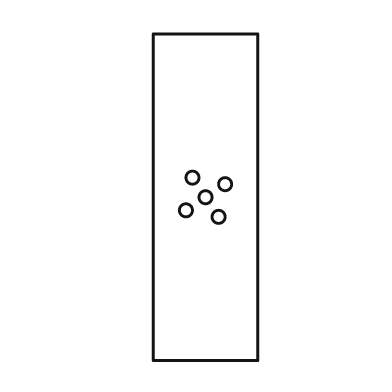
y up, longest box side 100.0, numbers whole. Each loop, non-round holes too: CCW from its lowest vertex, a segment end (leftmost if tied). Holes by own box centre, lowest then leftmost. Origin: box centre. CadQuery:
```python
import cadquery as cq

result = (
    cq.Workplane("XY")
    .moveTo(-16.0, -50.0)
    .lineTo(16.0, -50.0)
    .lineTo(16.0, 50.0)
    .lineTo(-16.0, 50.0)
    .close()
    .moveTo(4.0, -6.0)
    .circle(2.0)
    .moveTo(-6.0, -4.0)
    .circle(2.0)
    .moveTo(0.0, 0.0)
    .circle(2.0)
    .moveTo(6.0, 4.0)
    .circle(2.0)
    .moveTo(-4.0, 6.0)
    .circle(2.0)
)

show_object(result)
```